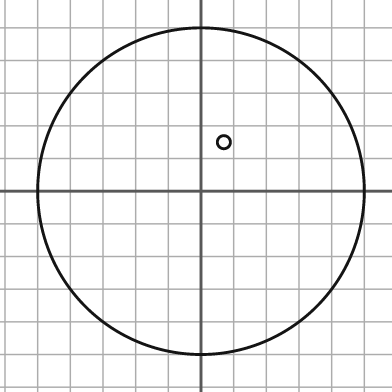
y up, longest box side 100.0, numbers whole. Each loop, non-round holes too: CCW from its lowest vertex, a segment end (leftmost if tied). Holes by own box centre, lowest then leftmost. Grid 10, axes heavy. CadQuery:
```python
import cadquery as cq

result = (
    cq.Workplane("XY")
    .moveTo(0.0, 0.0)
    .circle(50.0)
    .moveTo(7.0, 15.0)
    .circle(2.0)
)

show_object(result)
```